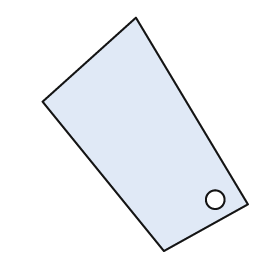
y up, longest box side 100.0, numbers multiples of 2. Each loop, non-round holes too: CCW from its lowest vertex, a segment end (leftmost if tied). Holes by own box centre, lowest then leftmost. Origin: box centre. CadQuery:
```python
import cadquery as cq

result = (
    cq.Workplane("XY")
    .moveTo(8.0, -50.0)
    .lineTo(44.0, -30.0)
    .lineTo(-4.0, 50.0)
    .lineTo(-44.0, 14.0)
    .close()
    .moveTo(30.0, -28.0)
    .circle(4.0)
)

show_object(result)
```